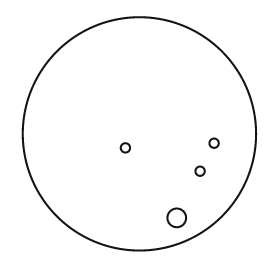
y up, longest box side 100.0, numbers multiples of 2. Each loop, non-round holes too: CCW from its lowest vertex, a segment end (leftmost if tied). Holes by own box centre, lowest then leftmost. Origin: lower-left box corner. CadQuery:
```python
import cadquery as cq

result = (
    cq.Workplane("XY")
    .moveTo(50.0, 50.0)
    .circle(50.0)
    .moveTo(66.0, 14.0)
    .circle(4.0)
    .moveTo(76.0, 34.0)
    .circle(2.0)
    .moveTo(44.0, 44.0)
    .circle(2.0)
    .moveTo(82.0, 46.0)
    .circle(2.0)
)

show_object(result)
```